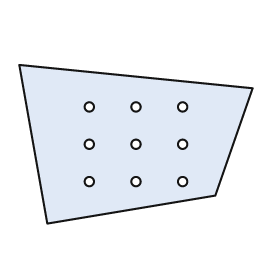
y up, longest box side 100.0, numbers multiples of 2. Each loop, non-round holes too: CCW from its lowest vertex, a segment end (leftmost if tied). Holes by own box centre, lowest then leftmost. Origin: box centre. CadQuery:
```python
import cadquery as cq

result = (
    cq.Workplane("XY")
    .moveTo(-38.0, -34.0)
    .lineTo(34.0, -22.0)
    .lineTo(50.0, 24.0)
    .lineTo(-50.0, 34.0)
    .close()
    .moveTo(-20.0, -16.0)
    .circle(2.0)
    .moveTo(0.0, -16.0)
    .circle(2.0)
    .moveTo(20.0, -16.0)
    .circle(2.0)
    .moveTo(-20.0, 0.0)
    .circle(2.0)
    .moveTo(0.0, 0.0)
    .circle(2.0)
    .moveTo(20.0, 0.0)
    .circle(2.0)
    .moveTo(-20.0, 16.0)
    .circle(2.0)
    .moveTo(0.0, 16.0)
    .circle(2.0)
    .moveTo(20.0, 16.0)
    .circle(2.0)
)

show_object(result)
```